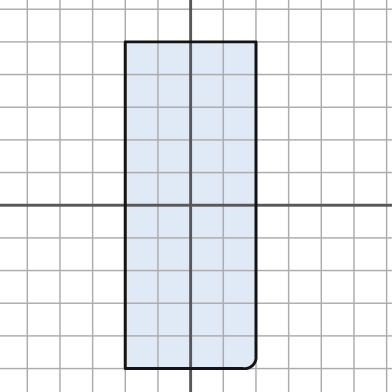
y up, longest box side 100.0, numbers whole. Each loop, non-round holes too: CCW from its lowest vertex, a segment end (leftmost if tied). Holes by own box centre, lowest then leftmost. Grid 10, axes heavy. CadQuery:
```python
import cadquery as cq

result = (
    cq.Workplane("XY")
    .moveTo(-20.0, -50.0)
    .lineTo(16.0, -50.0)
    .threePointArc((19.0, -49.0), (20.0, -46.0))
    .lineTo(20.0, 50.0)
    .lineTo(-20.0, 50.0)
    .close()
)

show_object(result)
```